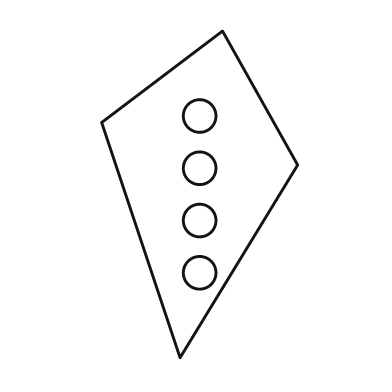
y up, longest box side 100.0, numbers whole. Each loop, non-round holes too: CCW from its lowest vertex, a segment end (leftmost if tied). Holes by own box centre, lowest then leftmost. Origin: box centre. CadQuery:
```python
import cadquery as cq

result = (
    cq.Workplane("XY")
    .moveTo(-6.0, -50.0)
    .lineTo(30.0, 9.0)
    .lineTo(7.0, 50.0)
    .lineTo(-30.0, 22.0)
    .close()
    .moveTo(0.0, -24.0)
    .circle(5.0)
    .moveTo(0.0, -8.0)
    .circle(5.0)
    .moveTo(0.0, 8.0)
    .circle(5.0)
    .moveTo(0.0, 24.0)
    .circle(5.0)
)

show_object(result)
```